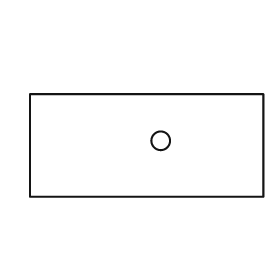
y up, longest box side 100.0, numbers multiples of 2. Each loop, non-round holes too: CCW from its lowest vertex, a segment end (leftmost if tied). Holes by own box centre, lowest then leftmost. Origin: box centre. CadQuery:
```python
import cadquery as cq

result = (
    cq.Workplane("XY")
    .moveTo(-50.0, -22.0)
    .lineTo(50.0, -22.0)
    .lineTo(50.0, 22.0)
    .lineTo(-50.0, 22.0)
    .close()
    .moveTo(6.0, 2.0)
    .circle(4.0)
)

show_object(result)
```